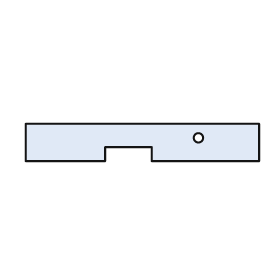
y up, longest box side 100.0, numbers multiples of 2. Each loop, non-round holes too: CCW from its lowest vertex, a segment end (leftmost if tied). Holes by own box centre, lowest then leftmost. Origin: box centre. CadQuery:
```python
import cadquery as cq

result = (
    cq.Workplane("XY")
    .moveTo(-50.0, -8.0)
    .lineTo(-16.0, -8.0)
    .lineTo(-16.0, -2.0)
    .lineTo(4.0, -2.0)
    .lineTo(4.0, -8.0)
    .lineTo(50.0, -8.0)
    .lineTo(50.0, 8.0)
    .lineTo(-50.0, 8.0)
    .close()
    .moveTo(24.0, 2.0)
    .circle(2.0)
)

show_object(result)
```